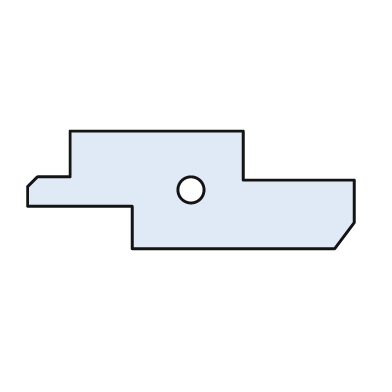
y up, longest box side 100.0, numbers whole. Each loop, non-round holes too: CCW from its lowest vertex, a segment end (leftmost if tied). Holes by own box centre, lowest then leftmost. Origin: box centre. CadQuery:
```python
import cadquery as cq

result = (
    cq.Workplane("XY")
    .moveTo(-18.0, -18.0)
    .lineTo(44.0, -18.0)
    .lineTo(50.0, -10.0)
    .lineTo(50.0, 3.0)
    .lineTo(16.0, 3.0)
    .lineTo(16.0, 18.0)
    .lineTo(-37.0, 18.0)
    .lineTo(-37.0, 4.0)
    .lineTo(-47.0, 4.0)
    .lineTo(-50.0, 1.0)
    .lineTo(-50.0, -5.0)
    .lineTo(-18.0, -5.0)
    .close()
    .moveTo(0.0, 0.0)
    .circle(4.0)
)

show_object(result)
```